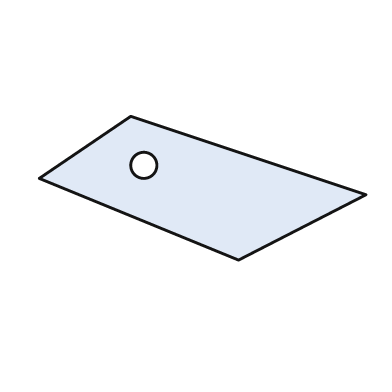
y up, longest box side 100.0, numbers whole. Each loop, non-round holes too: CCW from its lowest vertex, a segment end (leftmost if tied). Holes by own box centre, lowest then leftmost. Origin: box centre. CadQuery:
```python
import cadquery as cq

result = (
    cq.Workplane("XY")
    .moveTo(11.0, -22.0)
    .lineTo(50.0, -2.0)
    .lineTo(-22.0, 22.0)
    .lineTo(-50.0, 3.0)
    .close()
    .moveTo(-18.0, 7.0)
    .circle(4.0)
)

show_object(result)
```